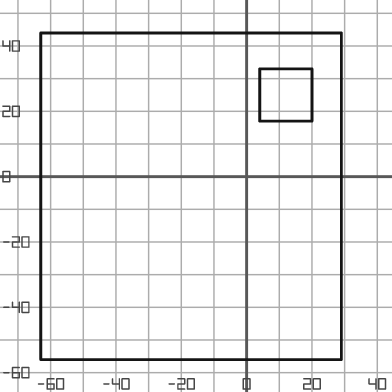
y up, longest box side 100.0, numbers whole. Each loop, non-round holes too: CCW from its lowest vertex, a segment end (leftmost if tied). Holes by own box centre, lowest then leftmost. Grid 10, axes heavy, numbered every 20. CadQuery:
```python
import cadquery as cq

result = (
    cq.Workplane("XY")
    .moveTo(-63.0, -56.0)
    .lineTo(29.0, -56.0)
    .lineTo(29.0, 44.0)
    .lineTo(-63.0, 44.0)
    .close()
    .moveTo(4.0, 17.0)
    .lineTo(20.0, 17.0)
    .lineTo(20.0, 33.0)
    .lineTo(4.0, 33.0)
    .close()
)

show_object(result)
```